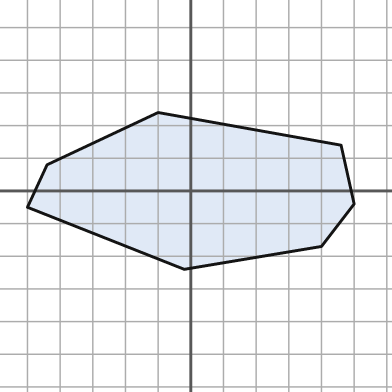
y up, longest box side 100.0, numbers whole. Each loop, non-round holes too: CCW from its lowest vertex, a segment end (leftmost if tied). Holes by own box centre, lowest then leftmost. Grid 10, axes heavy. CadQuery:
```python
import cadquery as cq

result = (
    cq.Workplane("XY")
    .moveTo(-2.0, -24.0)
    .lineTo(40.0, -17.0)
    .lineTo(50.0, -4.0)
    .lineTo(46.0, 14.0)
    .lineTo(-10.0, 24.0)
    .lineTo(-44.0, 8.0)
    .lineTo(-50.0, -5.0)
    .close()
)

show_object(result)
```